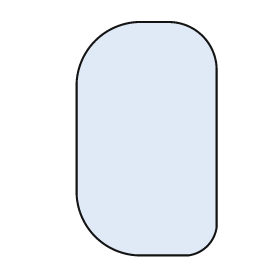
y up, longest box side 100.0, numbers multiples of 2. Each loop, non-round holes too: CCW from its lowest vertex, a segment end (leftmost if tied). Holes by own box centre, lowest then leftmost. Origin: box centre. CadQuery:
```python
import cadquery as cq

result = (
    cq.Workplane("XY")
    .moveTo(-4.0, -50.0)
    .lineTo(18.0, -50.0)
    .threePointArc((26.0, -46.0), (30.0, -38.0))
    .lineTo(30.0, 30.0)
    .threePointArc((24.0, 44.0), (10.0, 50.0))
    .lineTo(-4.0, 50.0)
    .threePointArc((-22.0, 42.0), (-30.0, 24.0))
    .lineTo(-30.0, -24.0)
    .threePointArc((-22.0, -42.0), (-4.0, -50.0))
    .close()
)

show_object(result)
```